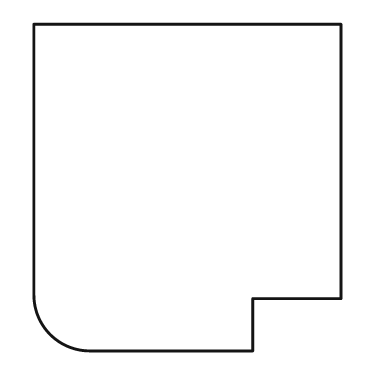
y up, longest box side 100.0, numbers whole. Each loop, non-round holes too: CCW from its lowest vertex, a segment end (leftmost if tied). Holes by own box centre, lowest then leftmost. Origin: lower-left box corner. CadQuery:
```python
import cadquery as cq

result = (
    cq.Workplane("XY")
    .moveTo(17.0, 0.0)
    .lineTo(67.0, 0.0)
    .lineTo(67.0, 16.0)
    .lineTo(94.0, 16.0)
    .lineTo(94.0, 100.0)
    .lineTo(0.0, 100.0)
    .lineTo(0.0, 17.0)
    .threePointArc((5.0, 5.0), (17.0, 0.0))
    .close()
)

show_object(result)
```